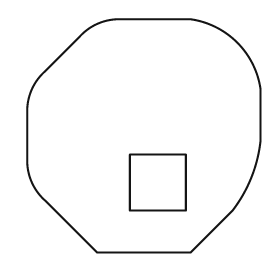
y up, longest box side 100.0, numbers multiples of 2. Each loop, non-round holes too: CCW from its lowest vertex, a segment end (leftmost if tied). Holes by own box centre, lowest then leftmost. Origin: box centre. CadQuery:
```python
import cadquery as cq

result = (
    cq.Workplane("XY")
    .moveTo(-20.0, -50.0)
    .lineTo(20.0, -50.0)
    .lineTo(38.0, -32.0)
    .threePointArc((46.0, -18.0), (50.0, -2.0))
    .lineTo(50.0, 20.0)
    .threePointArc((40.0, 40.0), (20.0, 50.0))
    .lineTo(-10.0, 50.0)
    .threePointArc((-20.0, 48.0), (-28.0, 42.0))
    .lineTo(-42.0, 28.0)
    .threePointArc((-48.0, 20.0), (-50.0, 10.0))
    .lineTo(-50.0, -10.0)
    .threePointArc((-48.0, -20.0), (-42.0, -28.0))
    .close()
    .moveTo(-6.0, -32.0)
    .lineTo(18.0, -32.0)
    .lineTo(18.0, -8.0)
    .lineTo(-6.0, -8.0)
    .close()
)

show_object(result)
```